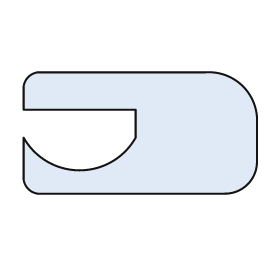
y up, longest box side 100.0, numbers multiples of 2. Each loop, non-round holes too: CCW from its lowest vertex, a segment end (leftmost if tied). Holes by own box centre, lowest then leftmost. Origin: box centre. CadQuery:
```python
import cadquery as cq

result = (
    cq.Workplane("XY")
    .moveTo(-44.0, -26.0)
    .lineTo(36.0, -26.0)
    .threePointArc((46.0, -22.0), (50.0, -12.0))
    .lineTo(50.0, 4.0)
    .threePointArc((44.0, 20.0), (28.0, 26.0))
    .lineTo(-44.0, 26.0)
    .threePointArc((-48.0, 24.0), (-50.0, 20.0))
    .lineTo(-50.0, 10.0)
    .lineTo(-2.0, 10.0)
    .lineTo(-2.0, -2.0)
    .threePointArc((-26.0, -16.0), (-50.0, -2.0))
    .lineTo(-50.0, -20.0)
    .threePointArc((-48.0, -24.0), (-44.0, -26.0))
    .close()
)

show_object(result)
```